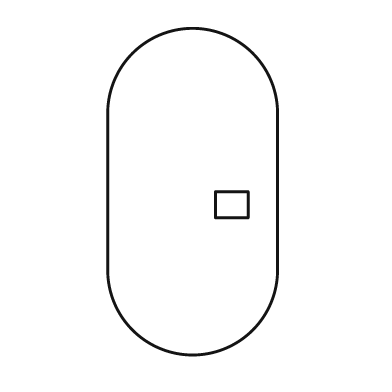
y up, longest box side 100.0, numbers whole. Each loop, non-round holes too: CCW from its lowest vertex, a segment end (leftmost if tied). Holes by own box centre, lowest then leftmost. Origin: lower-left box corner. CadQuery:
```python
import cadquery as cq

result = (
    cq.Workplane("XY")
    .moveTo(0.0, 26.0)
    .threePointArc((26.0, 0.0), (52.0, 26.0))
    .lineTo(52.0, 74.0)
    .threePointArc((26.0, 100.0), (0.0, 74.0))
    .close()
    .moveTo(33.0, 42.0)
    .lineTo(43.0, 42.0)
    .lineTo(43.0, 50.0)
    .lineTo(33.0, 50.0)
    .close()
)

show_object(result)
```